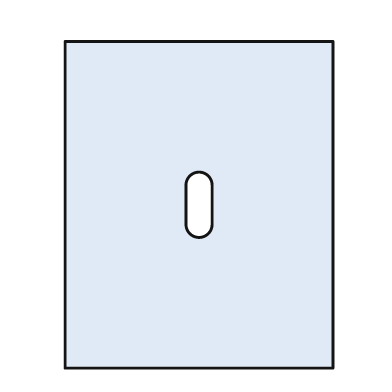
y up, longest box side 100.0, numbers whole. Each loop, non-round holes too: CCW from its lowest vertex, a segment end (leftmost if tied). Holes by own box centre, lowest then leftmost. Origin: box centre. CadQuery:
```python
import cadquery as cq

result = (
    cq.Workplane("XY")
    .moveTo(-41.0, -50.0)
    .lineTo(41.0, -50.0)
    .lineTo(41.0, 50.0)
    .lineTo(-41.0, 50.0)
    .close()
    .moveTo(-4.0, -6.0)
    .threePointArc((0.0, -10.0), (4.0, -6.0))
    .lineTo(4.0, 6.0)
    .threePointArc((0.0, 10.0), (-4.0, 6.0))
    .close()
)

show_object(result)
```